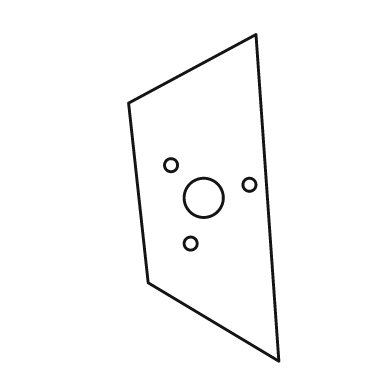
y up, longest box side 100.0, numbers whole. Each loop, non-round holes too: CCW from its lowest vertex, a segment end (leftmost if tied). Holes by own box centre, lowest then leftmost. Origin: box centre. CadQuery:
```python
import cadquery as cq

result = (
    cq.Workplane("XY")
    .moveTo(23.0, -50.0)
    .lineTo(16.0, 50.0)
    .lineTo(-23.0, 29.0)
    .lineTo(-17.0, -26.0)
    .close()
    .moveTo(-4.0, -14.0)
    .circle(2.0)
    .moveTo(0.0, 0.0)
    .circle(6.0)
    .moveTo(14.0, 4.0)
    .circle(2.0)
    .moveTo(-10.0, 10.0)
    .circle(2.0)
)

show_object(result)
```